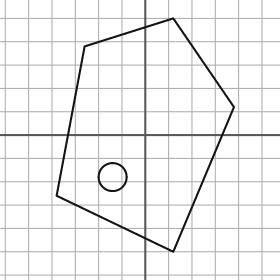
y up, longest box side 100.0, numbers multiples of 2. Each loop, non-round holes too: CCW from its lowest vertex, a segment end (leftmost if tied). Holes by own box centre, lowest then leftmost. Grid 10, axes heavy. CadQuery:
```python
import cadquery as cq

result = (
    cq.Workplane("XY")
    .moveTo(12.0, -50.0)
    .lineTo(38.0, 12.0)
    .lineTo(12.0, 50.0)
    .lineTo(-26.0, 38.0)
    .lineTo(-38.0, -26.0)
    .close()
    .moveTo(-14.0, -18.0)
    .circle(6.0)
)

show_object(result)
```